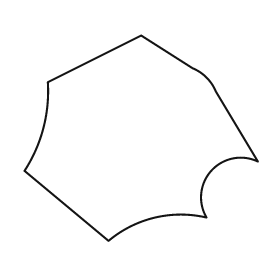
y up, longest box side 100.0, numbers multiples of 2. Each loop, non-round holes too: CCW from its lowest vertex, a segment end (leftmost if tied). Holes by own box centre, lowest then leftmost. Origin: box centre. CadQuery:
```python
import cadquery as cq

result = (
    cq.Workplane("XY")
    .moveTo(-14.0, -44.0)
    .threePointArc((6.0, -34.0), (28.0, -34.0))
    .threePointArc((30.0, -14.0), (50.0, -10.0))
    .lineTo(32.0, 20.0)
    .threePointArc((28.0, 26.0), (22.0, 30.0))
    .lineTo(0.0, 44.0)
    .lineTo(-40.0, 24.0)
    .threePointArc((-42.0, 4.0), (-50.0, -14.0))
    .close()
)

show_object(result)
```